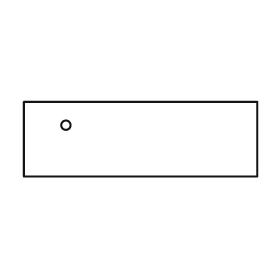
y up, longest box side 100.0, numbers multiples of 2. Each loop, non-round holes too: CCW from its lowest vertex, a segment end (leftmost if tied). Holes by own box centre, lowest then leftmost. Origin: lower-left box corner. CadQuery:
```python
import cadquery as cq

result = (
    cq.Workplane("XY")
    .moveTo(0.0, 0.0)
    .lineTo(100.0, 0.0)
    .lineTo(100.0, 32.0)
    .lineTo(0.0, 32.0)
    .close()
    .moveTo(18.0, 22.0)
    .circle(2.0)
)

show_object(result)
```